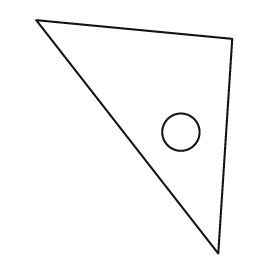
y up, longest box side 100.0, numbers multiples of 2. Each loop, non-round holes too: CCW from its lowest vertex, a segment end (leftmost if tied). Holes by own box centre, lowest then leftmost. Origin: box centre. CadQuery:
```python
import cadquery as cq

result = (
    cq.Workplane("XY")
    .moveTo(36.0, -50.0)
    .lineTo(42.0, 42.0)
    .lineTo(-42.0, 50.0)
    .close()
    .moveTo(20.0, 2.0)
    .circle(8.0)
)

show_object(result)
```